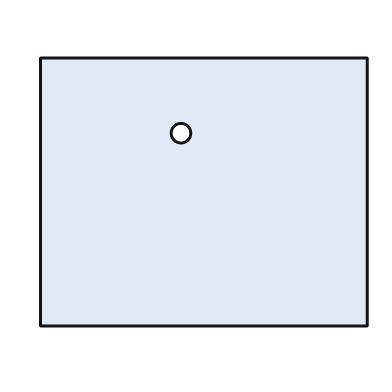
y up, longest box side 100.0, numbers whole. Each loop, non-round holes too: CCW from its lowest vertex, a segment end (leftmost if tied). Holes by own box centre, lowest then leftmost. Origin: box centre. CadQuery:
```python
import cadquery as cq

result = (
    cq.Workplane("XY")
    .moveTo(-50.0, -41.0)
    .lineTo(50.0, -41.0)
    .lineTo(50.0, 41.0)
    .lineTo(-50.0, 41.0)
    .close()
    .moveTo(-7.0, 18.0)
    .circle(3.0)
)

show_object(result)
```